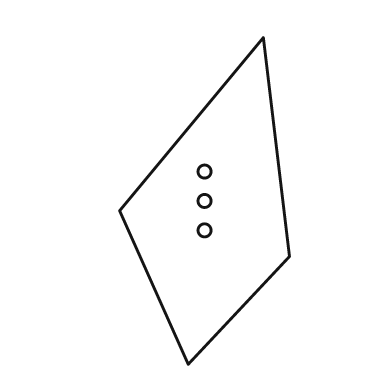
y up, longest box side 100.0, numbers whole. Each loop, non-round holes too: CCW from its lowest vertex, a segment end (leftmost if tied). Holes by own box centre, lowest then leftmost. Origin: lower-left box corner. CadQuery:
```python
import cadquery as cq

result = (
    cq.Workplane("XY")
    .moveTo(21.0, 0.0)
    .lineTo(52.0, 33.0)
    .lineTo(44.0, 100.0)
    .lineTo(0.0, 47.0)
    .close()
    .moveTo(26.0, 41.0)
    .circle(2.0)
    .moveTo(26.0, 50.0)
    .circle(2.0)
    .moveTo(26.0, 59.0)
    .circle(2.0)
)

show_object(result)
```